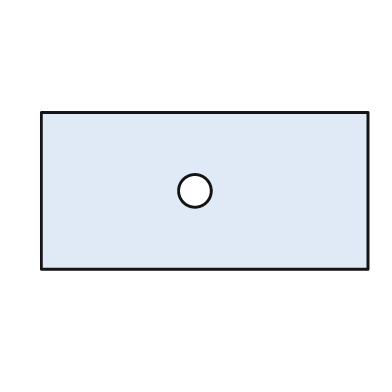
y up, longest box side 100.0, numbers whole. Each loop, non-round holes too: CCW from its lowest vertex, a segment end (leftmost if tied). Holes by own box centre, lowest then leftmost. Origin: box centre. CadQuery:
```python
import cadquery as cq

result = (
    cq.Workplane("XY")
    .moveTo(-50.0, -24.0)
    .lineTo(50.0, -24.0)
    .lineTo(50.0, 24.0)
    .lineTo(-50.0, 24.0)
    .close()
    .moveTo(-3.0, 0.0)
    .circle(5.0)
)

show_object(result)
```